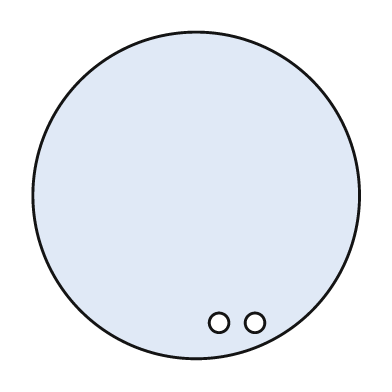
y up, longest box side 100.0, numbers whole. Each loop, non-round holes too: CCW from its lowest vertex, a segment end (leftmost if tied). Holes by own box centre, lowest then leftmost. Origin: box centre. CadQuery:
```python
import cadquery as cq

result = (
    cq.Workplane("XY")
    .moveTo(0.0, 0.0)
    .circle(50.0)
    .moveTo(7.0, -39.0)
    .circle(3.0)
    .moveTo(18.0, -39.0)
    .circle(3.0)
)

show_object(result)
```